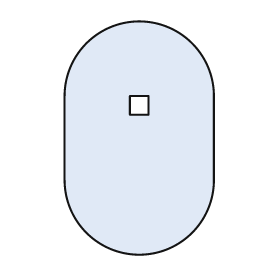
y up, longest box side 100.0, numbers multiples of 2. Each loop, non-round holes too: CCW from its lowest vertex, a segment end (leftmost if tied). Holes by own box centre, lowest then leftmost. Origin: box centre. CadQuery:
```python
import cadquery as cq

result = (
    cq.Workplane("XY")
    .moveTo(-32.0, -18.0)
    .threePointArc((0.0, -50.0), (32.0, -18.0))
    .lineTo(32.0, 18.0)
    .threePointArc((0.0, 50.0), (-32.0, 18.0))
    .close()
    .moveTo(-4.0, 10.0)
    .lineTo(4.0, 10.0)
    .lineTo(4.0, 18.0)
    .lineTo(-4.0, 18.0)
    .close()
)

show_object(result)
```